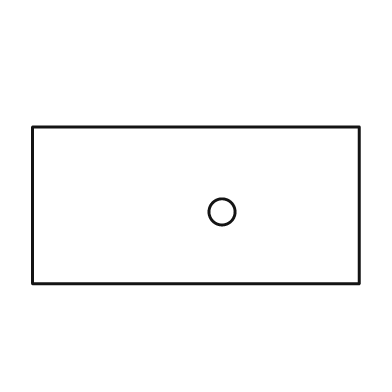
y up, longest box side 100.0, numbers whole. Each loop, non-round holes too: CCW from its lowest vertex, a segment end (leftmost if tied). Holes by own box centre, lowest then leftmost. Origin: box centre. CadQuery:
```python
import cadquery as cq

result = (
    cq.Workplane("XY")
    .moveTo(-50.0, -24.0)
    .lineTo(50.0, -24.0)
    .lineTo(50.0, 24.0)
    .lineTo(-50.0, 24.0)
    .close()
    .moveTo(8.0, -2.0)
    .circle(4.0)
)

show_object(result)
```